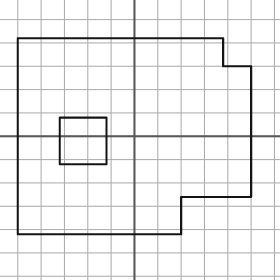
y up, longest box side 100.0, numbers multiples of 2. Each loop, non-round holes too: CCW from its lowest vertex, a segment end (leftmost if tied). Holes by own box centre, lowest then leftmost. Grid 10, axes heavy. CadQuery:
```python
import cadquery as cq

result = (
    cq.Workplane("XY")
    .moveTo(-50.0, -42.0)
    .lineTo(20.0, -42.0)
    .lineTo(20.0, -26.0)
    .lineTo(50.0, -26.0)
    .lineTo(50.0, 30.0)
    .lineTo(38.0, 30.0)
    .lineTo(38.0, 42.0)
    .lineTo(-50.0, 42.0)
    .close()
    .moveTo(-32.0, -12.0)
    .lineTo(-12.0, -12.0)
    .lineTo(-12.0, 8.0)
    .lineTo(-32.0, 8.0)
    .close()
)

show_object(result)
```